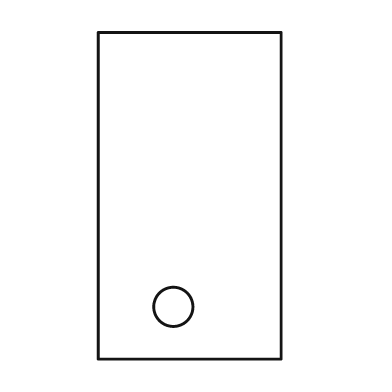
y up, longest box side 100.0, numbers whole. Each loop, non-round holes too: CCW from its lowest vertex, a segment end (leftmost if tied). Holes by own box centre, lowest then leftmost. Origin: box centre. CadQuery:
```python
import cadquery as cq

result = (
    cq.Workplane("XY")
    .moveTo(-28.0, -50.0)
    .lineTo(28.0, -50.0)
    .lineTo(28.0, 50.0)
    .lineTo(-28.0, 50.0)
    .close()
    .moveTo(-5.0, -34.0)
    .circle(6.0)
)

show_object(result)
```